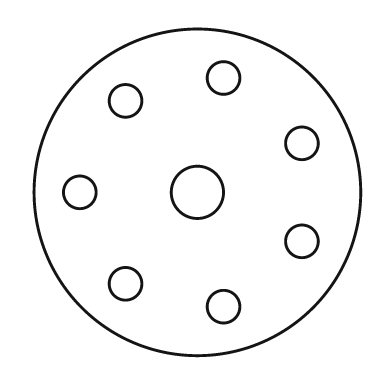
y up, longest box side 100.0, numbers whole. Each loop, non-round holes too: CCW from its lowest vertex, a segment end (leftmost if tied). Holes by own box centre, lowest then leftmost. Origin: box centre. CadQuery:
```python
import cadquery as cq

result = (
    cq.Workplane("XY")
    .moveTo(0.0, 0.0)
    .circle(50.0)
    .moveTo(8.0, -35.0)
    .circle(5.0)
    .moveTo(-22.0, -28.0)
    .circle(5.0)
    .moveTo(32.0, -15.0)
    .circle(5.0)
    .moveTo(-36.0, 0.0)
    .circle(5.0)
    .moveTo(0.0, 0.0)
    .circle(8.0)
    .moveTo(32.0, 15.0)
    .circle(5.0)
    .moveTo(-22.0, 28.0)
    .circle(5.0)
    .moveTo(8.0, 35.0)
    .circle(5.0)
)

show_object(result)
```